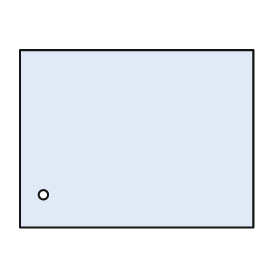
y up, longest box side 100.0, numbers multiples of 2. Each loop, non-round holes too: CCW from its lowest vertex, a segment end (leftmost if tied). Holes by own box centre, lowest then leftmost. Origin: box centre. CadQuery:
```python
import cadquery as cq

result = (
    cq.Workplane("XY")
    .moveTo(-50.0, -38.0)
    .lineTo(50.0, -38.0)
    .lineTo(50.0, 38.0)
    .lineTo(-50.0, 38.0)
    .close()
    .moveTo(-40.0, -24.0)
    .circle(2.0)
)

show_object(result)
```